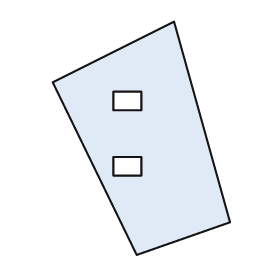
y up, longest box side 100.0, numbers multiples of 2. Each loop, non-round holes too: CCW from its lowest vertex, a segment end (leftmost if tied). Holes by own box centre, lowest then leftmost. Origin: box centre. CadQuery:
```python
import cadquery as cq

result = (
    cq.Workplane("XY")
    .moveTo(-2.0, -50.0)
    .lineTo(38.0, -36.0)
    .lineTo(14.0, 50.0)
    .lineTo(-38.0, 24.0)
    .close()
    .moveTo(-12.0, -16.0)
    .lineTo(0.0, -16.0)
    .lineTo(0.0, -8.0)
    .lineTo(-12.0, -8.0)
    .close()
    .moveTo(-12.0, 12.0)
    .lineTo(0.0, 12.0)
    .lineTo(0.0, 20.0)
    .lineTo(-12.0, 20.0)
    .close()
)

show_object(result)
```